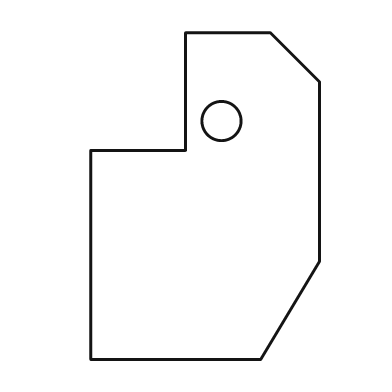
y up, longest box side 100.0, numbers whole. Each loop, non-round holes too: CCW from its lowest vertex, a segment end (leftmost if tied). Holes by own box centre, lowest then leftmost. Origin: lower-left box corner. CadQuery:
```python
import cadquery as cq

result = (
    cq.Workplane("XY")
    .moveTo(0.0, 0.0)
    .lineTo(52.0, 0.0)
    .lineTo(70.0, 30.0)
    .lineTo(70.0, 85.0)
    .lineTo(55.0, 100.0)
    .lineTo(29.0, 100.0)
    .lineTo(29.0, 64.0)
    .lineTo(0.0, 64.0)
    .close()
    .moveTo(40.0, 73.0)
    .circle(6.0)
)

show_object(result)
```